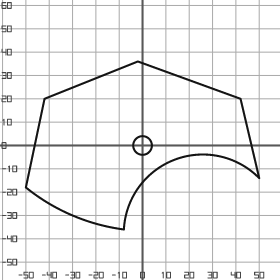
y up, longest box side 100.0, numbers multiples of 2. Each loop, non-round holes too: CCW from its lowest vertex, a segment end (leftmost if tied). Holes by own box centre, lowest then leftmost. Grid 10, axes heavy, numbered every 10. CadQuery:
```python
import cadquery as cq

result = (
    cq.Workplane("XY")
    .moveTo(-8.0, -36.0)
    .threePointArc((14.0, -6.0), (50.0, -14.0))
    .lineTo(42.0, 20.0)
    .lineTo(-2.0, 36.0)
    .lineTo(-42.0, 20.0)
    .lineTo(-50.0, -18.0)
    .threePointArc((-30.0, -30.0), (-8.0, -36.0))
    .close()
    .moveTo(0.0, 0.0)
    .circle(4.0)
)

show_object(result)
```